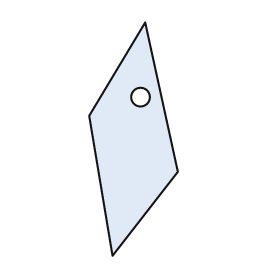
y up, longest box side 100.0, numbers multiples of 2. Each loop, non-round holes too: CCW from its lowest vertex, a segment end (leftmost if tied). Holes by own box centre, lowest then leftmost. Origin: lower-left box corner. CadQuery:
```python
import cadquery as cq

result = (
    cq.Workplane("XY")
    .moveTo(10.0, 0.0)
    .lineTo(38.0, 36.0)
    .lineTo(24.0, 100.0)
    .lineTo(0.0, 60.0)
    .close()
    .moveTo(22.0, 68.0)
    .circle(4.0)
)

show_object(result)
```